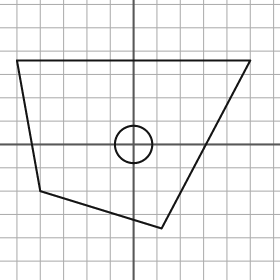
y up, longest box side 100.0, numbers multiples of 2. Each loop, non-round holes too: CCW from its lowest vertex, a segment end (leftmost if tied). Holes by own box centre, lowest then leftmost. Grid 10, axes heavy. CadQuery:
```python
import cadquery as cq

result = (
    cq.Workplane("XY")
    .moveTo(12.0, -36.0)
    .lineTo(50.0, 36.0)
    .lineTo(-50.0, 36.0)
    .lineTo(-40.0, -20.0)
    .close()
    .moveTo(0.0, 0.0)
    .circle(8.0)
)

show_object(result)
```